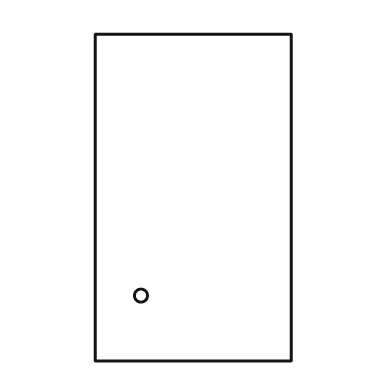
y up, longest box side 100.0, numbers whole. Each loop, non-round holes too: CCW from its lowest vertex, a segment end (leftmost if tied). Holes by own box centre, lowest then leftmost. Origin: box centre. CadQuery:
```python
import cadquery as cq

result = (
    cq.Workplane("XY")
    .moveTo(-30.0, -50.0)
    .lineTo(30.0, -50.0)
    .lineTo(30.0, 50.0)
    .lineTo(-30.0, 50.0)
    .close()
    .moveTo(-16.0, -30.0)
    .circle(2.0)
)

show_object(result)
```